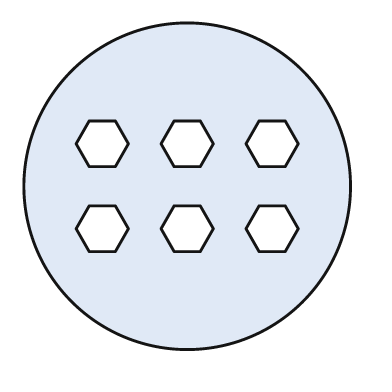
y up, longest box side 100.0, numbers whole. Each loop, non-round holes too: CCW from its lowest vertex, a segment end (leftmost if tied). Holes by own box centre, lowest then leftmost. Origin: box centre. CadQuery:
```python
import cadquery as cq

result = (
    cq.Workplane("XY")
    .moveTo(0.0, 0.0)
    .circle(50.0)
    .moveTo(-30.0, -20.0)
    .lineTo(-22.0, -20.0)
    .lineTo(-18.0, -13.0)
    .lineTo(-22.0, -6.0)
    .lineTo(-30.0, -6.0)
    .lineTo(-34.0, -13.0)
    .close()
    .moveTo(-4.0, -20.0)
    .lineTo(4.0, -20.0)
    .lineTo(8.0, -13.0)
    .lineTo(4.0, -6.0)
    .lineTo(-4.0, -6.0)
    .lineTo(-8.0, -13.0)
    .close()
    .moveTo(22.0, -20.0)
    .lineTo(30.0, -20.0)
    .lineTo(34.0, -13.0)
    .lineTo(30.0, -6.0)
    .lineTo(22.0, -6.0)
    .lineTo(18.0, -13.0)
    .close()
    .moveTo(-30.0, 6.0)
    .lineTo(-22.0, 6.0)
    .lineTo(-18.0, 13.0)
    .lineTo(-22.0, 20.0)
    .lineTo(-30.0, 20.0)
    .lineTo(-34.0, 13.0)
    .close()
    .moveTo(-4.0, 6.0)
    .lineTo(4.0, 6.0)
    .lineTo(8.0, 13.0)
    .lineTo(4.0, 20.0)
    .lineTo(-4.0, 20.0)
    .lineTo(-8.0, 13.0)
    .close()
    .moveTo(22.0, 6.0)
    .lineTo(30.0, 6.0)
    .lineTo(34.0, 13.0)
    .lineTo(30.0, 20.0)
    .lineTo(22.0, 20.0)
    .lineTo(18.0, 13.0)
    .close()
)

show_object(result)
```